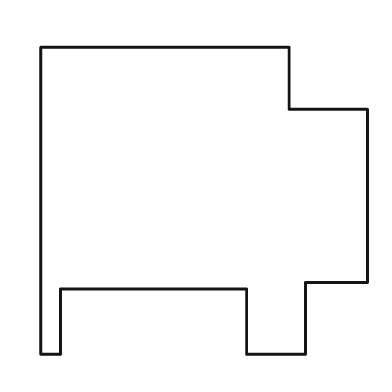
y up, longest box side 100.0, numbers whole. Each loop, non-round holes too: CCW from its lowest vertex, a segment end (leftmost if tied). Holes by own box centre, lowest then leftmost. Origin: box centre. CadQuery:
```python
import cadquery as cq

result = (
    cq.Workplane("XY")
    .moveTo(-50.0, -47.0)
    .lineTo(-44.0, -47.0)
    .lineTo(-44.0, -27.0)
    .lineTo(13.0, -27.0)
    .lineTo(13.0, -47.0)
    .lineTo(31.0, -47.0)
    .lineTo(31.0, -25.0)
    .lineTo(50.0, -25.0)
    .lineTo(50.0, 28.0)
    .lineTo(26.0, 28.0)
    .lineTo(26.0, 47.0)
    .lineTo(-50.0, 47.0)
    .close()
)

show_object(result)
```